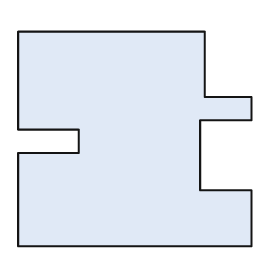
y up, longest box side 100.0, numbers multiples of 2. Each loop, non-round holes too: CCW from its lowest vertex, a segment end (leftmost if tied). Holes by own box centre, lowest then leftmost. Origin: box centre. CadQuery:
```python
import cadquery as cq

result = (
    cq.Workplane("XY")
    .moveTo(-50.0, -46.0)
    .lineTo(50.0, -46.0)
    .lineTo(50.0, -22.0)
    .lineTo(28.0, -22.0)
    .lineTo(28.0, 8.0)
    .lineTo(50.0, 8.0)
    .lineTo(50.0, 18.0)
    .lineTo(30.0, 18.0)
    .lineTo(30.0, 46.0)
    .lineTo(-50.0, 46.0)
    .lineTo(-50.0, 4.0)
    .lineTo(-24.0, 4.0)
    .lineTo(-24.0, -6.0)
    .lineTo(-50.0, -6.0)
    .close()
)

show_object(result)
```